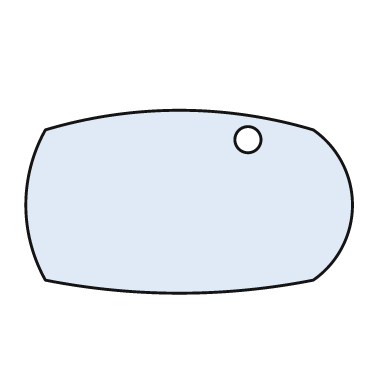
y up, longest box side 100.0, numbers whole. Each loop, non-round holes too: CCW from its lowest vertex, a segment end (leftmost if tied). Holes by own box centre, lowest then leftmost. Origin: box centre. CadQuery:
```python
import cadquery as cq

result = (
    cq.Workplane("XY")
    .moveTo(-44.0, -24.0)
    .threePointArc((-3.0, -28.0), (38.0, -24.0))
    .threePointArc((50.0, -1.0), (38.0, 22.0))
    .threePointArc((-3.0, 28.0), (-44.0, 22.0))
    .threePointArc((-50.0, -1.0), (-44.0, -24.0))
    .close()
    .moveTo(18.0, 19.0)
    .circle(4.0)
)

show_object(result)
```